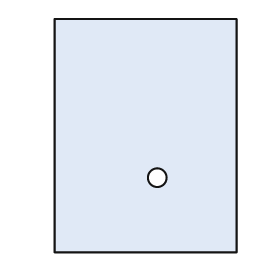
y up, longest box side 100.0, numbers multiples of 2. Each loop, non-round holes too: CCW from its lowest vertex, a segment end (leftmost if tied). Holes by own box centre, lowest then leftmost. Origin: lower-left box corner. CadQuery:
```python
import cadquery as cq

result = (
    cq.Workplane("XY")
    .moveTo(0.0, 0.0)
    .lineTo(78.0, 0.0)
    .lineTo(78.0, 100.0)
    .lineTo(0.0, 100.0)
    .close()
    .moveTo(44.0, 32.0)
    .circle(4.0)
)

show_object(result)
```